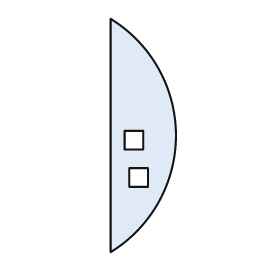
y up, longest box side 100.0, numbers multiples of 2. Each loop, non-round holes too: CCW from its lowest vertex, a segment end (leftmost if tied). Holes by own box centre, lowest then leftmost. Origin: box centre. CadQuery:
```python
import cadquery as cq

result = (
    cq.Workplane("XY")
    .moveTo(-14.0, -50.0)
    .threePointArc((14.0, 0.0), (-14.0, 50.0))
    .close()
    .moveTo(-6.0, -22.0)
    .lineTo(2.0, -22.0)
    .lineTo(2.0, -14.0)
    .lineTo(-6.0, -14.0)
    .close()
    .moveTo(-8.0, -6.0)
    .lineTo(0.0, -6.0)
    .lineTo(0.0, 2.0)
    .lineTo(-8.0, 2.0)
    .close()
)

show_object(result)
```